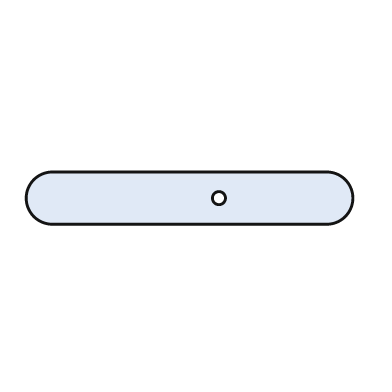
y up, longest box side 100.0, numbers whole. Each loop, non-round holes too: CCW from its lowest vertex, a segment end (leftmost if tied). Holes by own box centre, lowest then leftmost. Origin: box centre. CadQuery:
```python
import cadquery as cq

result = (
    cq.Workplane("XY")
    .moveTo(-42.0, -8.0)
    .lineTo(42.0, -8.0)
    .threePointArc((50.0, 0.0), (42.0, 8.0))
    .lineTo(-42.0, 8.0)
    .threePointArc((-50.0, 0.0), (-42.0, -8.0))
    .close()
    .moveTo(9.0, 0.0)
    .circle(2.0)
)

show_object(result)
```